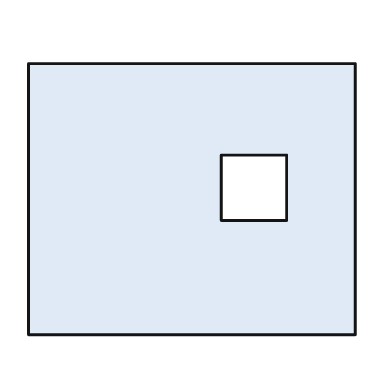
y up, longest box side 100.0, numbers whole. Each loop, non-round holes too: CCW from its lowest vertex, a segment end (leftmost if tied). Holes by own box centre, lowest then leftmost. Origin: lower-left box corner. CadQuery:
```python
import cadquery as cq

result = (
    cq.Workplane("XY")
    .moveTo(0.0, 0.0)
    .lineTo(100.0, 0.0)
    .lineTo(100.0, 83.0)
    .lineTo(0.0, 83.0)
    .close()
    .moveTo(59.0, 35.0)
    .lineTo(79.0, 35.0)
    .lineTo(79.0, 55.0)
    .lineTo(59.0, 55.0)
    .close()
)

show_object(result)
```